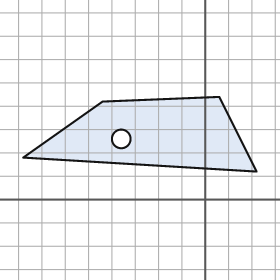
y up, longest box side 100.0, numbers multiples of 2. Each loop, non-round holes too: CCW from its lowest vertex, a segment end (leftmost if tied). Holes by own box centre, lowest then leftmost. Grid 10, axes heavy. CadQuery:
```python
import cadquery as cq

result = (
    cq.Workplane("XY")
    .moveTo(22.0, 12.0)
    .lineTo(6.0, 44.0)
    .lineTo(-44.0, 42.0)
    .lineTo(-78.0, 18.0)
    .close()
    .moveTo(-36.0, 26.0)
    .circle(4.0)
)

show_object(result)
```